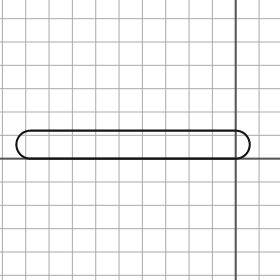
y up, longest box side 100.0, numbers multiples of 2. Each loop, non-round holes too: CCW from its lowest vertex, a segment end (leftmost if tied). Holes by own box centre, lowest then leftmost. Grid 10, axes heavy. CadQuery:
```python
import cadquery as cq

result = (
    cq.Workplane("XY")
    .moveTo(-88.0, 0.0)
    .lineTo(0.0, 0.0)
    .threePointArc((6.0, 6.0), (0.0, 12.0))
    .lineTo(-88.0, 12.0)
    .threePointArc((-94.0, 6.0), (-88.0, 0.0))
    .close()
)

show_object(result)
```